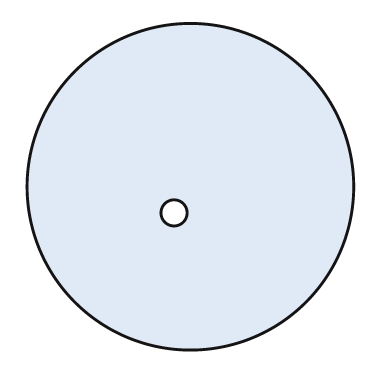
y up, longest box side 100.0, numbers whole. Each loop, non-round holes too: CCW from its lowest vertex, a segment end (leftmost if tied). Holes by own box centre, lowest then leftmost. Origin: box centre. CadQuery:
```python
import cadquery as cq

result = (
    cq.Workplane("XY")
    .moveTo(0.0, 0.0)
    .circle(50.0)
    .moveTo(-5.0, -8.0)
    .circle(4.0)
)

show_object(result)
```